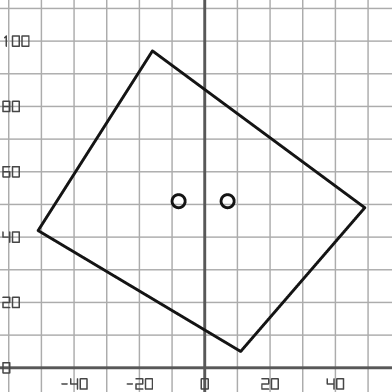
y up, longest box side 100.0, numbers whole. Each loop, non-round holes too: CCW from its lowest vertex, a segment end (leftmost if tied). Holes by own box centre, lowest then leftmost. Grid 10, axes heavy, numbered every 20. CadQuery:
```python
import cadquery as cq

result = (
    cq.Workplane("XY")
    .moveTo(11.0, 5.0)
    .lineTo(49.0, 49.0)
    .lineTo(-16.0, 97.0)
    .lineTo(-51.0, 42.0)
    .close()
    .moveTo(-8.0, 51.0)
    .circle(2.0)
    .moveTo(7.0, 51.0)
    .circle(2.0)
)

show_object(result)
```